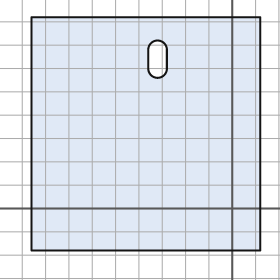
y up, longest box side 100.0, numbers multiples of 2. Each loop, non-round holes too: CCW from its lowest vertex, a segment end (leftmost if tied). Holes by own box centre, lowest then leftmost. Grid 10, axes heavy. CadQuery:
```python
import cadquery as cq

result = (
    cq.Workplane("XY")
    .moveTo(-86.0, -18.0)
    .lineTo(12.0, -18.0)
    .lineTo(12.0, 82.0)
    .lineTo(-86.0, 82.0)
    .close()
    .moveTo(-36.0, 60.0)
    .threePointArc((-32.0, 56.0), (-28.0, 60.0))
    .lineTo(-28.0, 68.0)
    .threePointArc((-32.0, 72.0), (-36.0, 68.0))
    .close()
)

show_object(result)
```